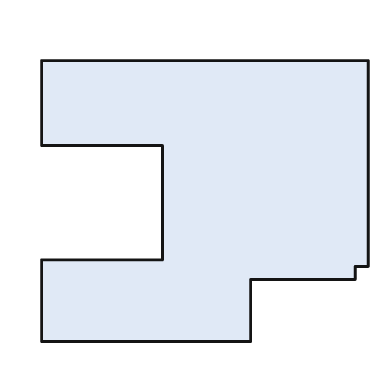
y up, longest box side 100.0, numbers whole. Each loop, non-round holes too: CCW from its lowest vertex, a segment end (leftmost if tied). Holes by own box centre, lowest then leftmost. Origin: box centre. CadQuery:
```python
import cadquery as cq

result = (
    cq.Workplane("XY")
    .moveTo(-50.0, -43.0)
    .lineTo(14.0, -43.0)
    .lineTo(14.0, -24.0)
    .lineTo(46.0, -24.0)
    .lineTo(46.0, -20.0)
    .lineTo(50.0, -20.0)
    .lineTo(50.0, 43.0)
    .lineTo(-50.0, 43.0)
    .lineTo(-50.0, 17.0)
    .lineTo(-13.0, 17.0)
    .lineTo(-13.0, -18.0)
    .lineTo(-50.0, -18.0)
    .close()
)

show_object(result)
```